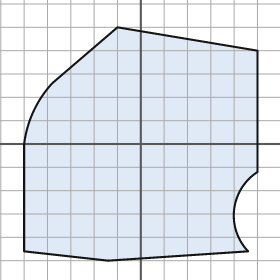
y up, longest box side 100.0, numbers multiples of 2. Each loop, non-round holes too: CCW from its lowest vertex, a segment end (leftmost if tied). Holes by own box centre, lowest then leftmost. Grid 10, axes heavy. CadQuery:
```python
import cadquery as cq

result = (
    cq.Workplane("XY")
    .moveTo(-14.0, -50.0)
    .lineTo(46.0, -46.0)
    .threePointArc((40.0, -28.0), (50.0, -12.0))
    .lineTo(50.0, 40.0)
    .lineTo(-10.0, 50.0)
    .lineTo(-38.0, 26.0)
    .threePointArc((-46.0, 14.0), (-50.0, 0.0))
    .lineTo(-50.0, -46.0)
    .close()
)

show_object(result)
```